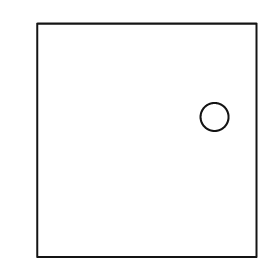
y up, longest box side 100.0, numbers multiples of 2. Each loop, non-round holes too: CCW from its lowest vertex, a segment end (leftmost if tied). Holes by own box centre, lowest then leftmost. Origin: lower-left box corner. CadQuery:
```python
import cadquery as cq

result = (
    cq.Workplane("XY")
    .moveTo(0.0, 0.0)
    .lineTo(94.0, 0.0)
    .lineTo(94.0, 100.0)
    .lineTo(0.0, 100.0)
    .close()
    .moveTo(76.0, 60.0)
    .circle(6.0)
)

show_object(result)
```